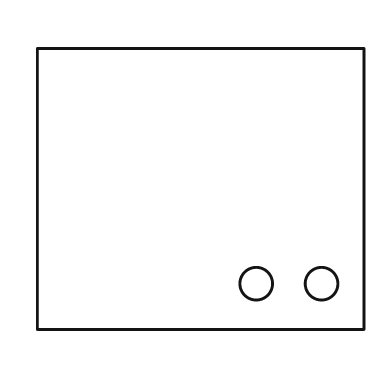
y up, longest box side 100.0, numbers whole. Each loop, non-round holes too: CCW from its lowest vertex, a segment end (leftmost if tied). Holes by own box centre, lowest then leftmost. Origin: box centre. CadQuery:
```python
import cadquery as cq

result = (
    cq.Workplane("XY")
    .moveTo(-50.0, -43.0)
    .lineTo(50.0, -43.0)
    .lineTo(50.0, 43.0)
    .lineTo(-50.0, 43.0)
    .close()
    .moveTo(17.0, -29.0)
    .circle(5.0)
    .moveTo(37.0, -29.0)
    .circle(5.0)
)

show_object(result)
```